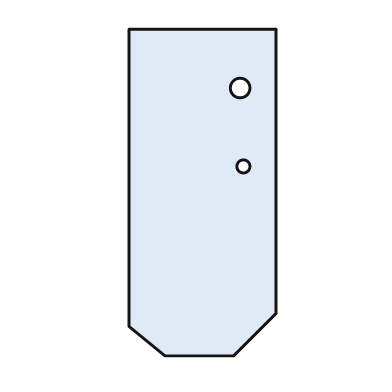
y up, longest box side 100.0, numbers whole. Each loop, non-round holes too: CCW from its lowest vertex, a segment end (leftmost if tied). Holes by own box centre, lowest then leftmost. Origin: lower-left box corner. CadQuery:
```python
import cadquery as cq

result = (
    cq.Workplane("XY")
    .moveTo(11.0, 0.0)
    .lineTo(32.0, 0.0)
    .lineTo(45.0, 13.0)
    .lineTo(45.0, 100.0)
    .lineTo(0.0, 100.0)
    .lineTo(0.0, 9.0)
    .close()
    .moveTo(35.0, 58.0)
    .circle(2.0)
    .moveTo(34.0, 82.0)
    .circle(3.0)
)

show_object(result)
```